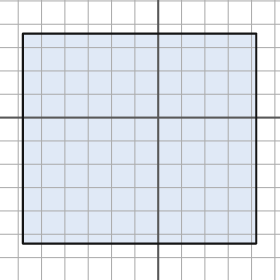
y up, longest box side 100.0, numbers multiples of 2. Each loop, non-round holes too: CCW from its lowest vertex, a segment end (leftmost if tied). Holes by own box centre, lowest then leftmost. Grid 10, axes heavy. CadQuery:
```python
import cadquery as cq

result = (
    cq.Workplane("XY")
    .moveTo(-58.0, -54.0)
    .lineTo(42.0, -54.0)
    .lineTo(42.0, 36.0)
    .lineTo(-58.0, 36.0)
    .close()
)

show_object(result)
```